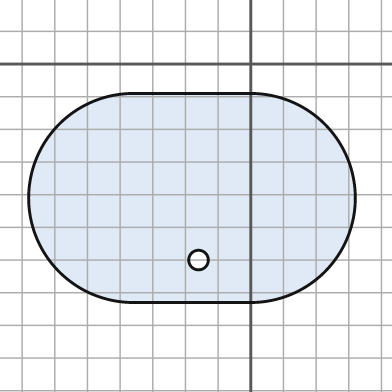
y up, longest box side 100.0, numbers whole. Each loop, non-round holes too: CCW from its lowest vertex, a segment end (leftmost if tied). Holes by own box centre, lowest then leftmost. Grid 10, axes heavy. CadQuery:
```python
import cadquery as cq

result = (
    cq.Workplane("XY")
    .moveTo(-36.0, -73.0)
    .lineTo(0.0, -73.0)
    .threePointArc((32.0, -41.0), (0.0, -9.0))
    .lineTo(-36.0, -9.0)
    .threePointArc((-68.0, -41.0), (-36.0, -73.0))
    .close()
    .moveTo(-16.0, -60.0)
    .circle(3.0)
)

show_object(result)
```